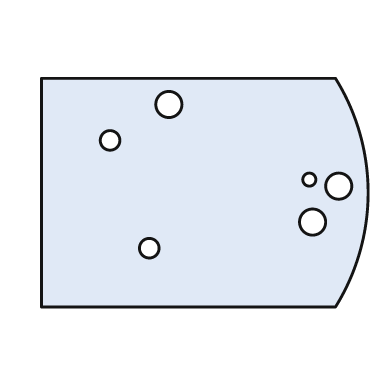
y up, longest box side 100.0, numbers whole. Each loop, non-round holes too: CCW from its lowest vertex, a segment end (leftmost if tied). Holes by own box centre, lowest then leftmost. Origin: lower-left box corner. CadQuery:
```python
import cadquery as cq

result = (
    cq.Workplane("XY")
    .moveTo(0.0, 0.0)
    .lineTo(90.0, 0.0)
    .threePointArc((100.0, 35.0), (90.0, 70.0))
    .lineTo(0.0, 70.0)
    .close()
    .moveTo(33.0, 18.0)
    .circle(3.0)
    .moveTo(83.0, 26.0)
    .circle(4.0)
    .moveTo(91.0, 37.0)
    .circle(4.0)
    .moveTo(82.0, 39.0)
    .circle(2.0)
    .moveTo(21.0, 51.0)
    .circle(3.0)
    .moveTo(39.0, 62.0)
    .circle(4.0)
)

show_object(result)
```